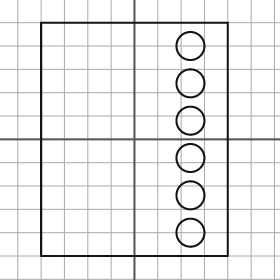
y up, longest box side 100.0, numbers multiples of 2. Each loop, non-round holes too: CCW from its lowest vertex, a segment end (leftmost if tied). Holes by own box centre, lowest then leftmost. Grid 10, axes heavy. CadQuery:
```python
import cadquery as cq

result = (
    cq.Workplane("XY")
    .moveTo(-40.0, -50.0)
    .lineTo(40.0, -50.0)
    .lineTo(40.0, 50.0)
    .lineTo(-40.0, 50.0)
    .close()
    .moveTo(24.0, -40.0)
    .circle(6.0)
    .moveTo(24.0, -24.0)
    .circle(6.0)
    .moveTo(24.0, -8.0)
    .circle(6.0)
    .moveTo(24.0, 8.0)
    .circle(6.0)
    .moveTo(24.0, 24.0)
    .circle(6.0)
    .moveTo(24.0, 40.0)
    .circle(6.0)
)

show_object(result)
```